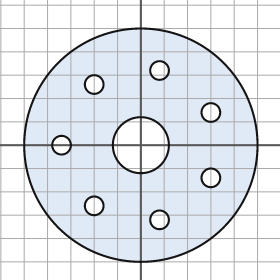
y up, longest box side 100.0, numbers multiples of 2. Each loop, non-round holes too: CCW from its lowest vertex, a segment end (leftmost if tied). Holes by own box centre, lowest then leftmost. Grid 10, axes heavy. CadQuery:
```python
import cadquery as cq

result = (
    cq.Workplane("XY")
    .moveTo(0.0, 0.0)
    .circle(50.0)
    .moveTo(8.0, -32.0)
    .circle(4.0)
    .moveTo(-20.0, -26.0)
    .circle(4.0)
    .moveTo(30.0, -14.0)
    .circle(4.0)
    .moveTo(-34.0, 0.0)
    .circle(4.0)
    .moveTo(0.0, 0.0)
    .circle(12.0)
    .moveTo(30.0, 14.0)
    .circle(4.0)
    .moveTo(-20.0, 26.0)
    .circle(4.0)
    .moveTo(8.0, 32.0)
    .circle(4.0)
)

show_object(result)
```